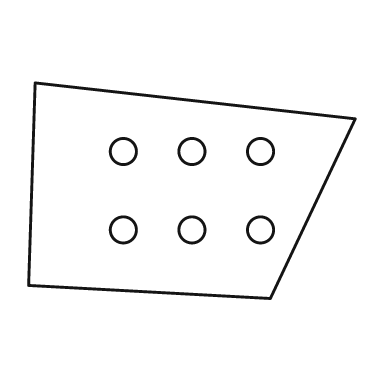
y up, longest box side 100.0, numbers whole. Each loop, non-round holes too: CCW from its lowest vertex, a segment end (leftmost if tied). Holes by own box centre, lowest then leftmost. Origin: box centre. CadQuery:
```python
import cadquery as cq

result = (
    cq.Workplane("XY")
    .moveTo(24.0, -33.0)
    .lineTo(50.0, 22.0)
    .lineTo(-48.0, 33.0)
    .lineTo(-50.0, -29.0)
    .close()
    .moveTo(-21.0, -12.0)
    .circle(4.0)
    .moveTo(0.0, -12.0)
    .circle(4.0)
    .moveTo(21.0, -12.0)
    .circle(4.0)
    .moveTo(-21.0, 12.0)
    .circle(4.0)
    .moveTo(0.0, 12.0)
    .circle(4.0)
    .moveTo(21.0, 12.0)
    .circle(4.0)
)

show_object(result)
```